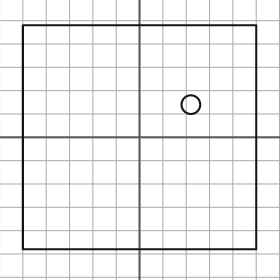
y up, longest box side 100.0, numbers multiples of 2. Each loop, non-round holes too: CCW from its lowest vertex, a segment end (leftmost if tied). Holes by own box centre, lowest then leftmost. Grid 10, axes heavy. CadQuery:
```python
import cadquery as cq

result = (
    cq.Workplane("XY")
    .moveTo(-50.0, -48.0)
    .lineTo(50.0, -48.0)
    .lineTo(50.0, 48.0)
    .lineTo(-50.0, 48.0)
    .close()
    .moveTo(22.0, 14.0)
    .circle(4.0)
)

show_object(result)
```